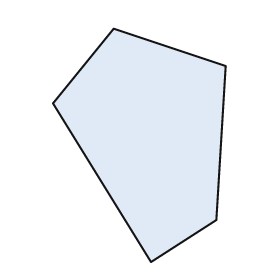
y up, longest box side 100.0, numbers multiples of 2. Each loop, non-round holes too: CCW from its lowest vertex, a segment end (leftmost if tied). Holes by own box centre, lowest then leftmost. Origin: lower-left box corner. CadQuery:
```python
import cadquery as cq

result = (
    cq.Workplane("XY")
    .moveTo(42.0, 0.0)
    .lineTo(70.0, 18.0)
    .lineTo(74.0, 84.0)
    .lineTo(26.0, 100.0)
    .lineTo(0.0, 68.0)
    .close()
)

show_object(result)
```